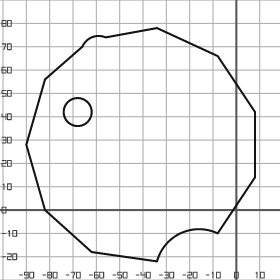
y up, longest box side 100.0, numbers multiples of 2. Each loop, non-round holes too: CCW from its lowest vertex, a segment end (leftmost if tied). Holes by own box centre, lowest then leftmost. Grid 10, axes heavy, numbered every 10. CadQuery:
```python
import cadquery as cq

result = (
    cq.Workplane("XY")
    .moveTo(-34.0, -22.0)
    .threePointArc((-24.0, -10.0), (-8.0, -10.0))
    .lineTo(8.0, 14.0)
    .lineTo(8.0, 42.0)
    .lineTo(-8.0, 66.0)
    .lineTo(-34.0, 78.0)
    .lineTo(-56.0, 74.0)
    .threePointArc((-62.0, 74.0), (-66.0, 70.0))
    .lineTo(-82.0, 56.0)
    .lineTo(-90.0, 28.0)
    .lineTo(-82.0, 0.0)
    .lineTo(-62.0, -18.0)
    .close()
    .moveTo(-68.0, 42.0)
    .circle(6.0)
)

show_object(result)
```